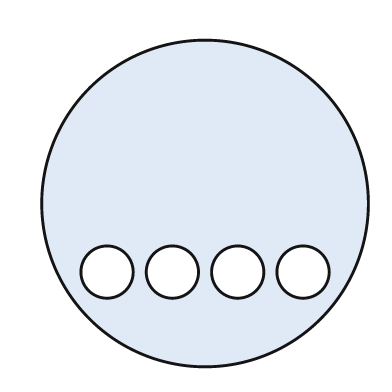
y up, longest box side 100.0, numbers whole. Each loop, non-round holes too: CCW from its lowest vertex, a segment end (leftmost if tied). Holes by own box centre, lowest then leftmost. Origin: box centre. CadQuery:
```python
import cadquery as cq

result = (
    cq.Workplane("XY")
    .moveTo(0.0, 0.0)
    .circle(50.0)
    .moveTo(-30.0, -21.0)
    .circle(8.0)
    .moveTo(-10.0, -21.0)
    .circle(8.0)
    .moveTo(10.0, -21.0)
    .circle(8.0)
    .moveTo(30.0, -21.0)
    .circle(8.0)
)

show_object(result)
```